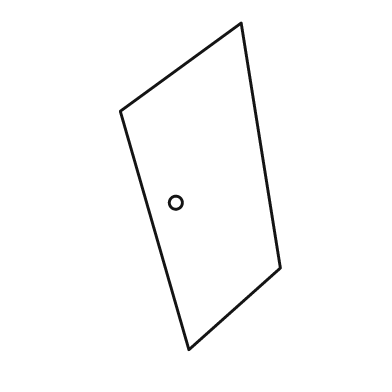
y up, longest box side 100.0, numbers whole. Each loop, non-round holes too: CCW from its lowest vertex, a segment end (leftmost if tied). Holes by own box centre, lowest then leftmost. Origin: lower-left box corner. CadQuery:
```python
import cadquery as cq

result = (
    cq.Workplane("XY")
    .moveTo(21.0, 0.0)
    .lineTo(49.0, 25.0)
    .lineTo(37.0, 100.0)
    .lineTo(0.0, 73.0)
    .close()
    .moveTo(17.0, 45.0)
    .circle(2.0)
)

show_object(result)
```